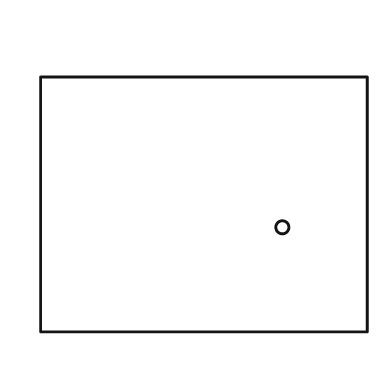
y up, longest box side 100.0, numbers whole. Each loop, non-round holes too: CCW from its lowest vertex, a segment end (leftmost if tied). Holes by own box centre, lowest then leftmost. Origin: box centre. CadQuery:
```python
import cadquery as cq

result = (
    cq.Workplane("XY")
    .moveTo(-50.0, -39.0)
    .lineTo(50.0, -39.0)
    .lineTo(50.0, 39.0)
    .lineTo(-50.0, 39.0)
    .close()
    .moveTo(24.0, -7.0)
    .circle(2.0)
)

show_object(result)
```